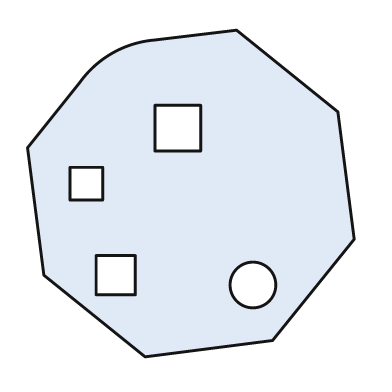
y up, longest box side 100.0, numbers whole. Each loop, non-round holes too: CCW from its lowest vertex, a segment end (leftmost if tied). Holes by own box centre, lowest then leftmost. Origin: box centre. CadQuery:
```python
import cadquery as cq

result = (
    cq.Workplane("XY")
    .moveTo(-14.0, -50.0)
    .lineTo(25.0, -45.0)
    .lineTo(50.0, -14.0)
    .lineTo(45.0, 25.0)
    .lineTo(14.0, 50.0)
    .lineTo(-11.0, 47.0)
    .threePointArc((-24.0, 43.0), (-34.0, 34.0))
    .lineTo(-50.0, 14.0)
    .lineTo(-45.0, -25.0)
    .close()
    .moveTo(19.0, -28.0)
    .circle(7.0)
    .moveTo(-29.0, -31.0)
    .lineTo(-17.0, -31.0)
    .lineTo(-17.0, -19.0)
    .lineTo(-29.0, -19.0)
    .close()
    .moveTo(-37.0, -2.0)
    .lineTo(-27.0, -2.0)
    .lineTo(-27.0, 8.0)
    .lineTo(-37.0, 8.0)
    .close()
    .moveTo(-11.0, 13.0)
    .lineTo(3.0, 13.0)
    .lineTo(3.0, 27.0)
    .lineTo(-11.0, 27.0)
    .close()
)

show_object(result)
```